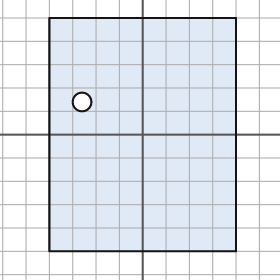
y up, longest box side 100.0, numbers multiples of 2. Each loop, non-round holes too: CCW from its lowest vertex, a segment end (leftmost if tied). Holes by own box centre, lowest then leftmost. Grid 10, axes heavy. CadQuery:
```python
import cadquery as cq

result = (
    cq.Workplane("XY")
    .moveTo(-40.0, -50.0)
    .lineTo(40.0, -50.0)
    .lineTo(40.0, 50.0)
    .lineTo(-40.0, 50.0)
    .close()
    .moveTo(-26.0, 14.0)
    .circle(4.0)
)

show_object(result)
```